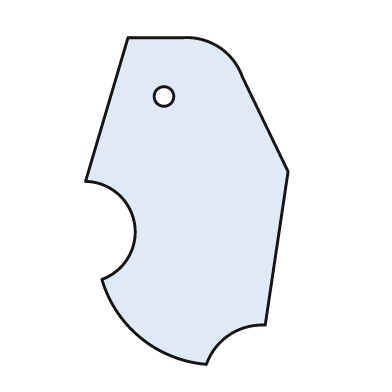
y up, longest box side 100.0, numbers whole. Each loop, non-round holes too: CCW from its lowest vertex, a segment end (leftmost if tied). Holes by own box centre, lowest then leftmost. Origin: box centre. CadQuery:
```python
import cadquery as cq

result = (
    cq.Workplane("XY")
    .moveTo(6.0, -50.0)
    .threePointArc((13.0, -41.0), (24.0, -38.0))
    .lineTo(31.0, 9.0)
    .lineTo(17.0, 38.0)
    .threePointArc((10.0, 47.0), (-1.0, 50.0))
    .lineTo(-18.0, 50.0)
    .lineTo(-31.0, 6.0)
    .threePointArc((-16.0, -7.0), (-26.0, -24.0))
    .threePointArc((-14.0, -42.0), (6.0, -50.0))
    .close()
    .moveTo(-7.0, 32.0)
    .circle(3.0)
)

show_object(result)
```